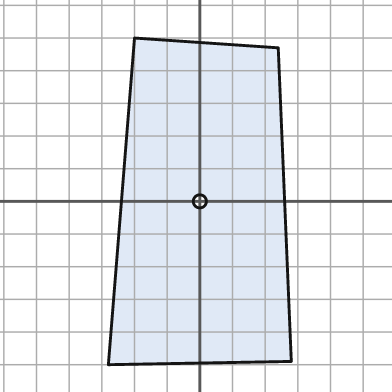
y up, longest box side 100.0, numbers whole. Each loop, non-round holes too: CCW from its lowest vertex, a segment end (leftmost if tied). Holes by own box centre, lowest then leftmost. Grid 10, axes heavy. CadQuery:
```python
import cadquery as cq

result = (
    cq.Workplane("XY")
    .moveTo(-28.0, -50.0)
    .lineTo(28.0, -49.0)
    .lineTo(24.0, 47.0)
    .lineTo(-20.0, 50.0)
    .close()
    .moveTo(0.0, 0.0)
    .circle(2.0)
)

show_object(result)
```